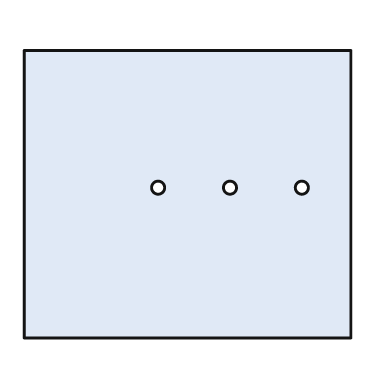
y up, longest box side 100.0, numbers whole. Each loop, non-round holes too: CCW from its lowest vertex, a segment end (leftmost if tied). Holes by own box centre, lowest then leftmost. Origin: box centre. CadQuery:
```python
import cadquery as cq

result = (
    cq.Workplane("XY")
    .moveTo(-50.0, -44.0)
    .lineTo(50.0, -44.0)
    .lineTo(50.0, 44.0)
    .lineTo(-50.0, 44.0)
    .close()
    .moveTo(-9.0, 2.0)
    .circle(2.0)
    .moveTo(13.0, 2.0)
    .circle(2.0)
    .moveTo(35.0, 2.0)
    .circle(2.0)
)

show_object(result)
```